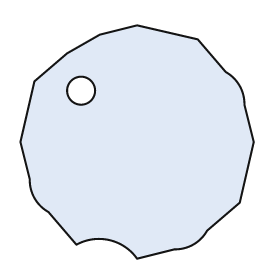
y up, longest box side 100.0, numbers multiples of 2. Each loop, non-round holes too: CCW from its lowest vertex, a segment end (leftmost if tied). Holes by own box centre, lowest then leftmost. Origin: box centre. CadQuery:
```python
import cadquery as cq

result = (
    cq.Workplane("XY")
    .moveTo(0.0, -50.0)
    .lineTo(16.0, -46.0)
    .threePointArc((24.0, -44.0), (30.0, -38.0))
    .lineTo(44.0, -26.0)
    .lineTo(50.0, 0.0)
    .lineTo(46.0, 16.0)
    .threePointArc((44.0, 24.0), (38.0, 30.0))
    .lineTo(26.0, 44.0)
    .lineTo(0.0, 50.0)
    .lineTo(-16.0, 46.0)
    .lineTo(-30.0, 38.0)
    .lineTo(-44.0, 26.0)
    .lineTo(-50.0, 0.0)
    .lineTo(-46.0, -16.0)
    .threePointArc((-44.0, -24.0), (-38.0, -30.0))
    .lineTo(-26.0, -44.0)
    .threePointArc((-12.0, -42.0), (0.0, -50.0))
    .close()
    .moveTo(-24.0, 22.0)
    .circle(6.0)
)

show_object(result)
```